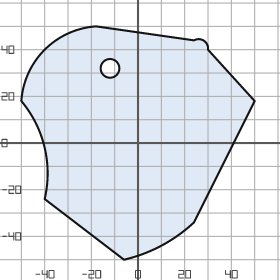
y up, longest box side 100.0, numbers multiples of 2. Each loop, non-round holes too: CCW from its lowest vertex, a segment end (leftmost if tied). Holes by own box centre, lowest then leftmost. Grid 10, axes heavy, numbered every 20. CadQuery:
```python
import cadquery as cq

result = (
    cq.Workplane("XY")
    .moveTo(-6.0, -50.0)
    .threePointArc((10.0, -44.0), (24.0, -34.0))
    .lineTo(50.0, 18.0)
    .lineTo(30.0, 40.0)
    .threePointArc((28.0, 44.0), (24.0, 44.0))
    .lineTo(-18.0, 50.0)
    .threePointArc((-40.0, 40.0), (-50.0, 18.0))
    .threePointArc((-40.0, -2.0), (-40.0, -24.0))
    .close()
    .moveTo(-12.0, 32.0)
    .circle(4.0)
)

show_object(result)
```